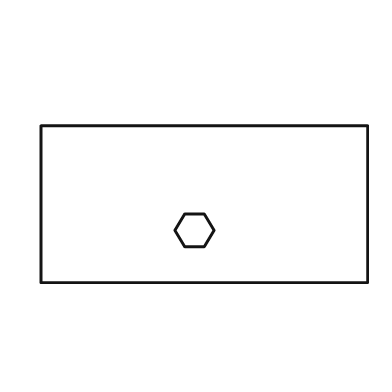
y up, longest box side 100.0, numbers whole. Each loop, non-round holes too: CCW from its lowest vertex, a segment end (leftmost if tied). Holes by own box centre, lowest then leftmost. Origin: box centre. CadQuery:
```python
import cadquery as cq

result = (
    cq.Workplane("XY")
    .moveTo(-50.0, -24.0)
    .lineTo(50.0, -24.0)
    .lineTo(50.0, 24.0)
    .lineTo(-50.0, 24.0)
    .close()
    .moveTo(-6.0, -13.0)
    .lineTo(0.0, -13.0)
    .lineTo(3.0, -8.0)
    .lineTo(0.0, -3.0)
    .lineTo(-6.0, -3.0)
    .lineTo(-9.0, -8.0)
    .close()
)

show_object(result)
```